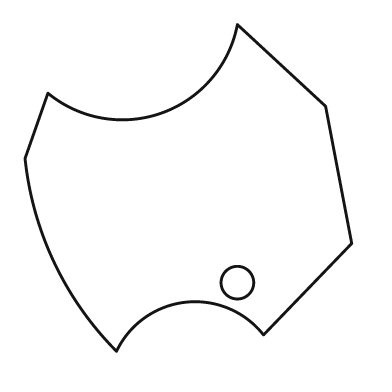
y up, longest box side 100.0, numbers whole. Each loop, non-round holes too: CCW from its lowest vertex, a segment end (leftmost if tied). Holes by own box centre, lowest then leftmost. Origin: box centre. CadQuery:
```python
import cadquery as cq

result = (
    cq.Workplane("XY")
    .moveTo(-22.0, -50.0)
    .threePointArc((-1.0, -35.0), (23.0, -45.0))
    .lineTo(50.0, -17.0)
    .lineTo(42.0, 25.0)
    .lineTo(15.0, 50.0)
    .threePointArc((-8.0, 23.0), (-43.0, 29.0))
    .lineTo(-50.0, 9.0)
    .threePointArc((-41.0, -23.0), (-22.0, -50.0))
    .close()
    .moveTo(15.0, -29.0)
    .circle(5.0)
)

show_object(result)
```